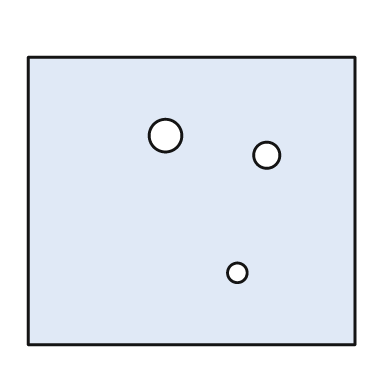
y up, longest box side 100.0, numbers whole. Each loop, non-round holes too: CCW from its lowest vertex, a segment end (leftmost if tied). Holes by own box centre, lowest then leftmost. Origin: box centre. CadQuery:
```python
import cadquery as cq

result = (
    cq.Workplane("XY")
    .moveTo(-50.0, -44.0)
    .lineTo(50.0, -44.0)
    .lineTo(50.0, 44.0)
    .lineTo(-50.0, 44.0)
    .close()
    .moveTo(14.0, -22.0)
    .circle(3.0)
    .moveTo(23.0, 14.0)
    .circle(4.0)
    .moveTo(-8.0, 20.0)
    .circle(5.0)
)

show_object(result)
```